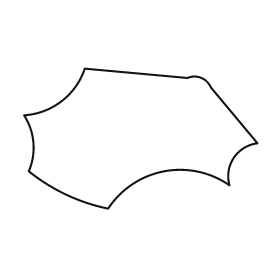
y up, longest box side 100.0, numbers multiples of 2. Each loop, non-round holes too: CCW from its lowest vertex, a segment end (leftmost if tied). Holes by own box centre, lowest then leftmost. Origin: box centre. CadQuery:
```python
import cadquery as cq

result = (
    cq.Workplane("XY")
    .moveTo(-14.0, -30.0)
    .threePointArc((10.0, -14.0), (38.0, -20.0))
    .threePointArc((40.0, -8.0), (50.0, -2.0))
    .lineTo(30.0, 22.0)
    .threePointArc((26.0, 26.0), (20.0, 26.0))
    .lineTo(-24.0, 30.0)
    .threePointArc((-34.0, 16.0), (-50.0, 10.0))
    .threePointArc((-46.0, -2.0), (-48.0, -14.0))
    .threePointArc((-32.0, -24.0), (-14.0, -30.0))
    .close()
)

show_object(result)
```